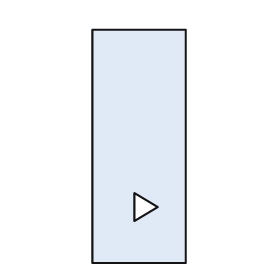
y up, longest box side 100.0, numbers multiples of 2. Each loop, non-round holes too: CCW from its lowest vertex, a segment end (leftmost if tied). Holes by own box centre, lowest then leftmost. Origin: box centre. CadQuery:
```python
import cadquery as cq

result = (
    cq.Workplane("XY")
    .moveTo(-20.0, -50.0)
    .lineTo(20.0, -50.0)
    .lineTo(20.0, 50.0)
    .lineTo(-20.0, 50.0)
    .close()
    .moveTo(-2.0, -32.0)
    .lineTo(8.0, -26.0)
    .lineTo(-2.0, -20.0)
    .close()
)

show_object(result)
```